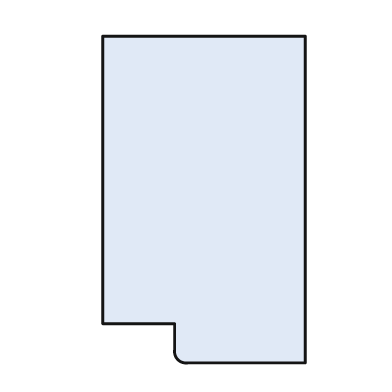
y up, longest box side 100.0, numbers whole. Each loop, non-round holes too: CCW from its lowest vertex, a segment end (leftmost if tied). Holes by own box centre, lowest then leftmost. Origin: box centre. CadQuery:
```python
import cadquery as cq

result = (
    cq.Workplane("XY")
    .moveTo(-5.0, -50.0)
    .lineTo(31.0, -50.0)
    .lineTo(31.0, 50.0)
    .lineTo(-31.0, 50.0)
    .lineTo(-31.0, -38.0)
    .lineTo(-9.0, -38.0)
    .lineTo(-9.0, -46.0)
    .threePointArc((-8.0, -49.0), (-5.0, -50.0))
    .close()
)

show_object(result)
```